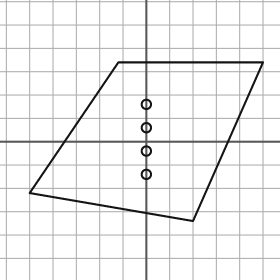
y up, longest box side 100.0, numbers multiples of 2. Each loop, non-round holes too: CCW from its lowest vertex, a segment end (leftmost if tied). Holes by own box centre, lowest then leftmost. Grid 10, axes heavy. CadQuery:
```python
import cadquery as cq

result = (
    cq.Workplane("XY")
    .moveTo(20.0, -34.0)
    .lineTo(50.0, 34.0)
    .lineTo(-12.0, 34.0)
    .lineTo(-50.0, -22.0)
    .close()
    .moveTo(0.0, -14.0)
    .circle(2.0)
    .moveTo(0.0, -4.0)
    .circle(2.0)
    .moveTo(0.0, 6.0)
    .circle(2.0)
    .moveTo(0.0, 16.0)
    .circle(2.0)
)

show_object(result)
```